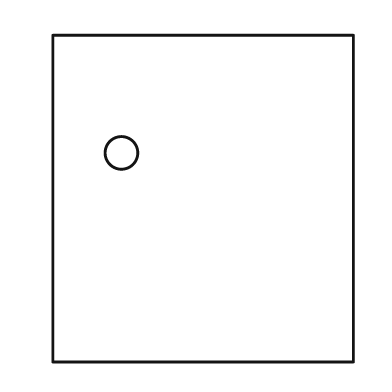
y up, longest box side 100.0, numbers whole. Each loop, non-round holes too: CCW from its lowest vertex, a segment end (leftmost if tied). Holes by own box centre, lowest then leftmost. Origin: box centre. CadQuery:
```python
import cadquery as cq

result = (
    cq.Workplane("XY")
    .moveTo(-46.0, -50.0)
    .lineTo(46.0, -50.0)
    .lineTo(46.0, 50.0)
    .lineTo(-46.0, 50.0)
    .close()
    .moveTo(-25.0, 14.0)
    .circle(5.0)
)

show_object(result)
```